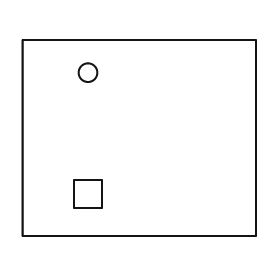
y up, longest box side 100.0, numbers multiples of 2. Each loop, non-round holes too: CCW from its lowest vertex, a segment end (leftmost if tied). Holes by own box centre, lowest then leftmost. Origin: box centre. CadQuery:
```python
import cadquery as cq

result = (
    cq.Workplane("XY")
    .moveTo(-50.0, -42.0)
    .lineTo(50.0, -42.0)
    .lineTo(50.0, 42.0)
    .lineTo(-50.0, 42.0)
    .close()
    .moveTo(-28.0, -30.0)
    .lineTo(-16.0, -30.0)
    .lineTo(-16.0, -18.0)
    .lineTo(-28.0, -18.0)
    .close()
    .moveTo(-22.0, 28.0)
    .circle(4.0)
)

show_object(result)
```